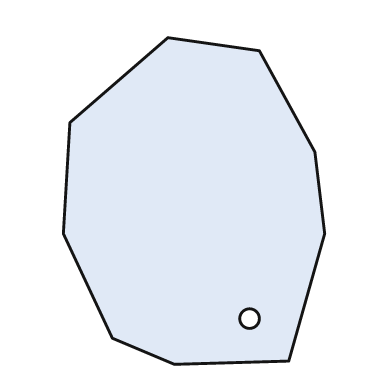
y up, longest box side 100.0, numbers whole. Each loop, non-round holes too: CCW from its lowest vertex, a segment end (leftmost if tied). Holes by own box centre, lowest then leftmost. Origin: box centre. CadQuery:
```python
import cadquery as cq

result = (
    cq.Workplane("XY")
    .moveTo(-6.0, -50.0)
    .lineTo(29.0, -49.0)
    .lineTo(40.0, -10.0)
    .lineTo(37.0, 15.0)
    .lineTo(20.0, 46.0)
    .lineTo(-8.0, 50.0)
    .lineTo(-38.0, 24.0)
    .lineTo(-40.0, -10.0)
    .lineTo(-25.0, -42.0)
    .close()
    .moveTo(17.0, -36.0)
    .circle(3.0)
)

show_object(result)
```